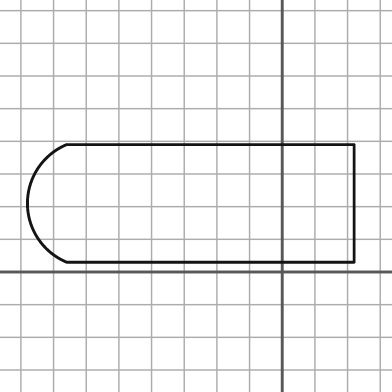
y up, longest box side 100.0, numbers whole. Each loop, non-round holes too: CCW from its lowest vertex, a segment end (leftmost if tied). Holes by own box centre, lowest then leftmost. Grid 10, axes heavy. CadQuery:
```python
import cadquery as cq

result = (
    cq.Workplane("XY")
    .moveTo(-66.0, 3.0)
    .lineTo(22.0, 3.0)
    .lineTo(22.0, 39.0)
    .lineTo(-66.0, 39.0)
    .threePointArc((-78.0, 21.0), (-66.0, 3.0))
    .close()
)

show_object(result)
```